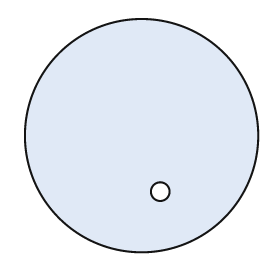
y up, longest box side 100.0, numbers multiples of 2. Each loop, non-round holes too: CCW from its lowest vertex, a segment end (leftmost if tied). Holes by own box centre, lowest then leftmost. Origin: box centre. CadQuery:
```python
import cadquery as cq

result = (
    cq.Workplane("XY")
    .moveTo(0.0, 0.0)
    .circle(50.0)
    .moveTo(8.0, -24.0)
    .circle(4.0)
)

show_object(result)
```